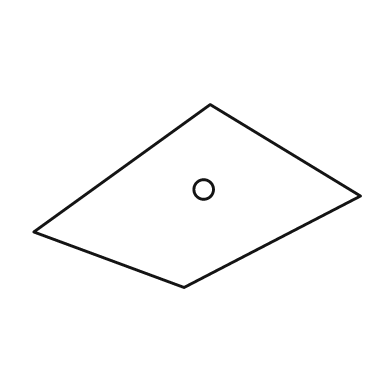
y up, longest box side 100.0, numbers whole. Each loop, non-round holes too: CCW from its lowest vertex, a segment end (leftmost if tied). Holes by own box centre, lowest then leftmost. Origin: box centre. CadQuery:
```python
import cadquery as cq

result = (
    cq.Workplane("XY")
    .moveTo(-4.0, -28.0)
    .lineTo(50.0, 0.0)
    .lineTo(4.0, 28.0)
    .lineTo(-50.0, -11.0)
    .close()
    .moveTo(2.0, 2.0)
    .circle(3.0)
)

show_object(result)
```